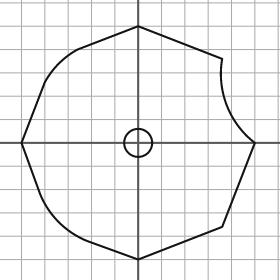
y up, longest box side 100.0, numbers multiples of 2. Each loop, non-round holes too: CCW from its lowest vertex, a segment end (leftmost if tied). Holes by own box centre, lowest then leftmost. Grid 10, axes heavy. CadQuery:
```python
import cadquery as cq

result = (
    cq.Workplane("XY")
    .moveTo(0.0, -50.0)
    .lineTo(36.0, -36.0)
    .lineTo(50.0, 0.0)
    .threePointArc((38.0, 16.0), (36.0, 36.0))
    .lineTo(0.0, 50.0)
    .lineTo(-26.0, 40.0)
    .threePointArc((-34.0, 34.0), (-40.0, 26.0))
    .lineTo(-50.0, 0.0)
    .lineTo(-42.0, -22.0)
    .threePointArc((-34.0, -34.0), (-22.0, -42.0))
    .close()
    .moveTo(0.0, 0.0)
    .circle(6.0)
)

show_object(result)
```